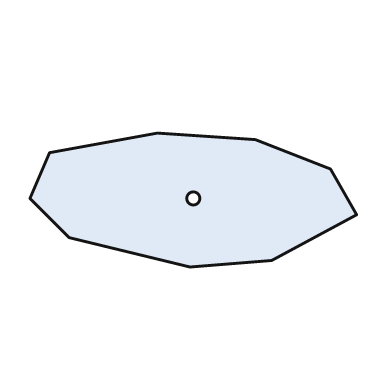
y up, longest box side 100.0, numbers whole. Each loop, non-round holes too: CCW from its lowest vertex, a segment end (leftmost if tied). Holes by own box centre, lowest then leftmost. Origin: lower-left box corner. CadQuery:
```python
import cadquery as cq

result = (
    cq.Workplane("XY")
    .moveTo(49.0, 0.0)
    .lineTo(74.0, 2.0)
    .lineTo(100.0, 16.0)
    .lineTo(92.0, 30.0)
    .lineTo(69.0, 39.0)
    .lineTo(39.0, 41.0)
    .lineTo(6.0, 35.0)
    .lineTo(0.0, 21.0)
    .lineTo(12.0, 9.0)
    .close()
    .moveTo(50.0, 21.0)
    .circle(2.0)
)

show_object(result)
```